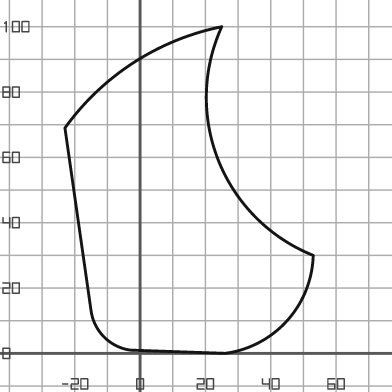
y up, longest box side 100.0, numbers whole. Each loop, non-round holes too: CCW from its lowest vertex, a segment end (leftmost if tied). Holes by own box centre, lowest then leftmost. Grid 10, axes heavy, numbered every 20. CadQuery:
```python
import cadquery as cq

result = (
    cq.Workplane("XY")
    .moveTo(26.0, 0.0)
    .threePointArc((45.0, 10.0), (53.0, 30.0))
    .threePointArc((24.0, 59.0), (25.0, 100.0))
    .threePointArc((-2.0, 89.0), (-23.0, 69.0))
    .lineTo(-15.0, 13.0)
    .threePointArc((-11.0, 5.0), (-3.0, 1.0))
    .close()
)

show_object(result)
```